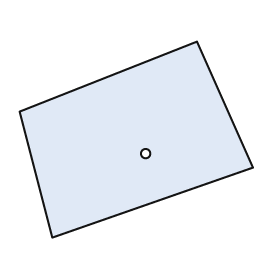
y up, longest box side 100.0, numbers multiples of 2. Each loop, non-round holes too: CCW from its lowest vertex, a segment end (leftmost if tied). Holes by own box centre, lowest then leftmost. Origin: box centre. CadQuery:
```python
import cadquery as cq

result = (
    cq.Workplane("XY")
    .moveTo(-36.0, -42.0)
    .lineTo(50.0, -12.0)
    .lineTo(26.0, 42.0)
    .lineTo(-50.0, 12.0)
    .close()
    .moveTo(4.0, -6.0)
    .circle(2.0)
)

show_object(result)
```